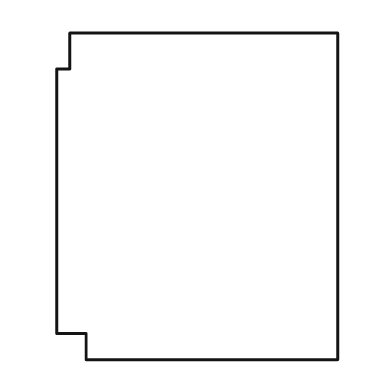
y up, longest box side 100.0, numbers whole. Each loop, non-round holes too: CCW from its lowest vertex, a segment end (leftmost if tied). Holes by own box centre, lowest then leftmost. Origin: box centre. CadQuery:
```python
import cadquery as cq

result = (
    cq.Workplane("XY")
    .moveTo(-34.0, -50.0)
    .lineTo(43.0, -50.0)
    .lineTo(43.0, 50.0)
    .lineTo(-39.0, 50.0)
    .lineTo(-39.0, 39.0)
    .lineTo(-43.0, 39.0)
    .lineTo(-43.0, -42.0)
    .lineTo(-34.0, -42.0)
    .close()
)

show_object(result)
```